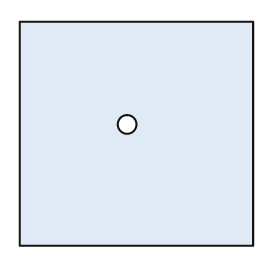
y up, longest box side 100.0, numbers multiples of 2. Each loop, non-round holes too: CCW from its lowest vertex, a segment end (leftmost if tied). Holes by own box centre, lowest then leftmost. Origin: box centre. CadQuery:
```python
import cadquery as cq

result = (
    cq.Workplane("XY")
    .moveTo(-50.0, -48.0)
    .lineTo(50.0, -48.0)
    .lineTo(50.0, 48.0)
    .lineTo(-50.0, 48.0)
    .close()
    .moveTo(-4.0, 4.0)
    .circle(4.0)
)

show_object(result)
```